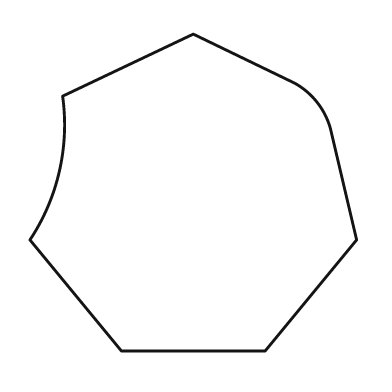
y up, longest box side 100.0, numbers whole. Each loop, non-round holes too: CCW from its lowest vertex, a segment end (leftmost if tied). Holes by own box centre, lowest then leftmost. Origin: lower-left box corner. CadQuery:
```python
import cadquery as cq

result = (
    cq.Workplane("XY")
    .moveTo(28.0, 0.0)
    .lineTo(72.0, 0.0)
    .lineTo(100.0, 34.0)
    .lineTo(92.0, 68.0)
    .threePointArc((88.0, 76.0), (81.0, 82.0))
    .lineTo(50.0, 97.0)
    .lineTo(10.0, 78.0)
    .threePointArc((9.0, 55.0), (0.0, 34.0))
    .close()
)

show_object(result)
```